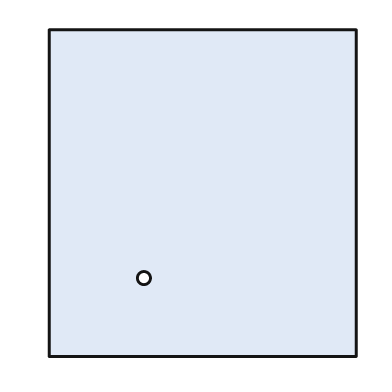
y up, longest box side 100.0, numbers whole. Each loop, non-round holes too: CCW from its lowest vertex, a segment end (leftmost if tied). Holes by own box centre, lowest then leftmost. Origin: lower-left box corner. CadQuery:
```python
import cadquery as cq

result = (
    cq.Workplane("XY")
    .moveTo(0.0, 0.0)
    .lineTo(94.0, 0.0)
    .lineTo(94.0, 100.0)
    .lineTo(0.0, 100.0)
    .close()
    .moveTo(29.0, 24.0)
    .circle(2.0)
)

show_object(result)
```